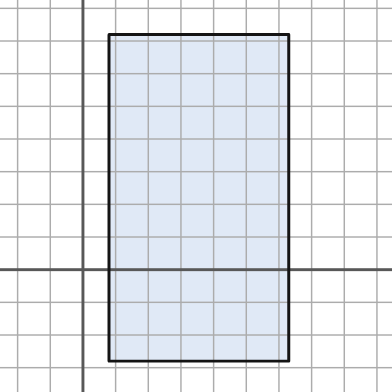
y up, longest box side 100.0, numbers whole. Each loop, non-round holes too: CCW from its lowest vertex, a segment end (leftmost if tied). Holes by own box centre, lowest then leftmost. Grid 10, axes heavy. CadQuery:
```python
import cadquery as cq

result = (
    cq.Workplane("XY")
    .moveTo(8.0, -28.0)
    .lineTo(63.0, -28.0)
    .lineTo(63.0, 72.0)
    .lineTo(8.0, 72.0)
    .close()
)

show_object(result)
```